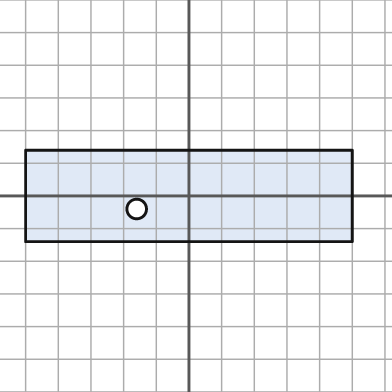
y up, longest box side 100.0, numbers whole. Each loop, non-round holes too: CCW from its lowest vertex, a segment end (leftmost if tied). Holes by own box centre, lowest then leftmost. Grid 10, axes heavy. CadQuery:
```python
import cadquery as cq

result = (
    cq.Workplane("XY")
    .moveTo(-50.0, -14.0)
    .lineTo(50.0, -14.0)
    .lineTo(50.0, 14.0)
    .lineTo(-50.0, 14.0)
    .close()
    .moveTo(-16.0, -4.0)
    .circle(3.0)
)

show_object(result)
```